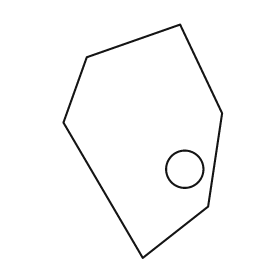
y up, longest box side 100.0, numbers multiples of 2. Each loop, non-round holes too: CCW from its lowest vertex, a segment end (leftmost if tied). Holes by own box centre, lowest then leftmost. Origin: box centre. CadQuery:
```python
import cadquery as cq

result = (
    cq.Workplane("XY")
    .moveTo(0.0, -50.0)
    .lineTo(28.0, -28.0)
    .lineTo(34.0, 12.0)
    .lineTo(16.0, 50.0)
    .lineTo(-24.0, 36.0)
    .lineTo(-34.0, 8.0)
    .close()
    .moveTo(18.0, -12.0)
    .circle(8.0)
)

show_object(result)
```